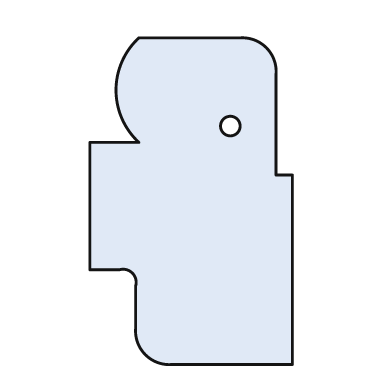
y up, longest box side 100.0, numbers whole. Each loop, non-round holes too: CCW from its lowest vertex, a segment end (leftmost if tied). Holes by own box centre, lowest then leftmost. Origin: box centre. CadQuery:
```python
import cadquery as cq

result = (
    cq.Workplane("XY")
    .moveTo(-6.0, -50.0)
    .lineTo(31.0, -50.0)
    .lineTo(31.0, 8.0)
    .lineTo(26.0, 8.0)
    .lineTo(26.0, 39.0)
    .threePointArc((23.0, 47.0), (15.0, 50.0))
    .lineTo(-16.0, 50.0)
    .threePointArc((-23.0, 34.0), (-16.0, 18.0))
    .lineTo(-31.0, 18.0)
    .lineTo(-31.0, -21.0)
    .lineTo(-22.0, -21.0)
    .threePointArc((-18.0, -22.0), (-17.0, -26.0))
    .lineTo(-17.0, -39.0)
    .threePointArc((-14.0, -47.0), (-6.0, -50.0))
    .close()
    .moveTo(12.0, 23.0)
    .circle(3.0)
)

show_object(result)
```